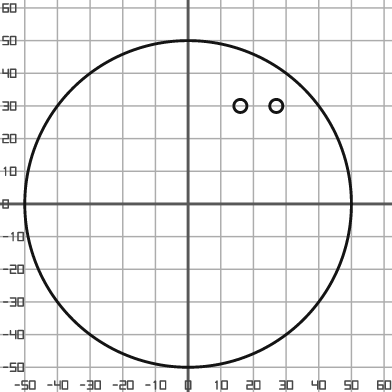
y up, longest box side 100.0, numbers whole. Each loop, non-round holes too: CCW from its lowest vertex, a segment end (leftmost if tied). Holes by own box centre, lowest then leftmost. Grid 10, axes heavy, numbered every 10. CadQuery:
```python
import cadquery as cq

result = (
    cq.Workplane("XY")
    .moveTo(0.0, 0.0)
    .circle(50.0)
    .moveTo(16.0, 30.0)
    .circle(2.0)
    .moveTo(27.0, 30.0)
    .circle(2.0)
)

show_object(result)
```